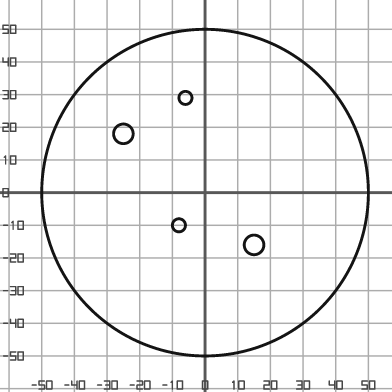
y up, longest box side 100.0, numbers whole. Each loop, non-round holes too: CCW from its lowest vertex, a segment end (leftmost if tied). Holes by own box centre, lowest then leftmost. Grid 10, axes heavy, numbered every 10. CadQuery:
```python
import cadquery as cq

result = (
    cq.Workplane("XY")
    .moveTo(0.0, 0.0)
    .circle(50.0)
    .moveTo(15.0, -16.0)
    .circle(3.0)
    .moveTo(-8.0, -10.0)
    .circle(2.0)
    .moveTo(-25.0, 18.0)
    .circle(3.0)
    .moveTo(-6.0, 29.0)
    .circle(2.0)
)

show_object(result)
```